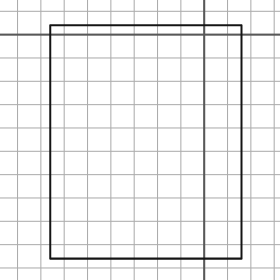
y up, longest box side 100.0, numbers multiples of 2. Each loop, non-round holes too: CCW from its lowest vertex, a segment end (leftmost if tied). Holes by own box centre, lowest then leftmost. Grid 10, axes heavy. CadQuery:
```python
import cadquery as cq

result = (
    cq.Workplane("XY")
    .moveTo(-66.0, -96.0)
    .lineTo(16.0, -96.0)
    .lineTo(16.0, 4.0)
    .lineTo(-66.0, 4.0)
    .close()
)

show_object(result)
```